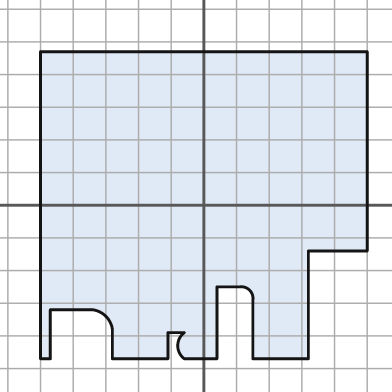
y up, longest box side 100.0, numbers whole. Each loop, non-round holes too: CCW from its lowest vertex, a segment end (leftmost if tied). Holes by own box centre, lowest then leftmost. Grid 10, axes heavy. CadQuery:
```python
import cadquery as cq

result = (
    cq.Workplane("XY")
    .moveTo(-50.0, -47.0)
    .lineTo(-47.0, -47.0)
    .lineTo(-47.0, -32.0)
    .lineTo(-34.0, -32.0)
    .threePointArc((-30.0, -34.0), (-28.0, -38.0))
    .lineTo(-28.0, -47.0)
    .lineTo(-11.0, -47.0)
    .lineTo(-11.0, -39.0)
    .lineTo(-6.0, -39.0)
    .threePointArc((-8.0, -43.0), (-6.0, -47.0))
    .lineTo(4.0, -47.0)
    .lineTo(4.0, -25.0)
    .lineTo(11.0, -25.0)
    .threePointArc((14.0, -26.0), (15.0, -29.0))
    .lineTo(15.0, -47.0)
    .lineTo(32.0, -47.0)
    .lineTo(32.0, -14.0)
    .lineTo(50.0, -14.0)
    .lineTo(50.0, 47.0)
    .lineTo(-50.0, 47.0)
    .close()
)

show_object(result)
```